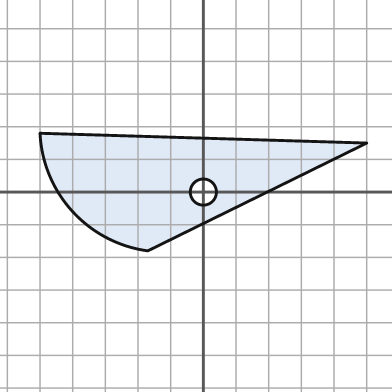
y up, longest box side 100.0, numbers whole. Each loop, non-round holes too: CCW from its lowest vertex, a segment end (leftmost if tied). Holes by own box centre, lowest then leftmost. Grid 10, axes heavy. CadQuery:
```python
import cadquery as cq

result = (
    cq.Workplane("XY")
    .moveTo(-17.0, -18.0)
    .lineTo(50.0, 15.0)
    .lineTo(-50.0, 18.0)
    .threePointArc((-40.0, -6.0), (-17.0, -18.0))
    .close()
    .moveTo(0.0, 0.0)
    .circle(4.0)
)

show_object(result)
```